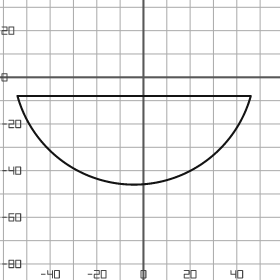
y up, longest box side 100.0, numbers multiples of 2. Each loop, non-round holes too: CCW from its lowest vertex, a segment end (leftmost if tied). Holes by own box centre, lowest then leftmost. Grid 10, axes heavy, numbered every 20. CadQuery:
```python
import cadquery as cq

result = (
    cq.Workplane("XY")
    .moveTo(-54.0, -8.0)
    .threePointArc((-4.0, -46.0), (46.0, -8.0))
    .close()
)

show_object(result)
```